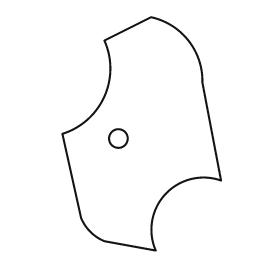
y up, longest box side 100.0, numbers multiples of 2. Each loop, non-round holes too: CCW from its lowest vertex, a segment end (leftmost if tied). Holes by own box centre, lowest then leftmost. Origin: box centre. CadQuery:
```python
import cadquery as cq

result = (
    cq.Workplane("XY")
    .moveTo(6.0, -50.0)
    .threePointArc((10.0, -26.0), (34.0, -20.0))
    .lineTo(26.0, 22.0)
    .threePointArc((20.0, 40.0), (4.0, 50.0))
    .lineTo(-16.0, 40.0)
    .threePointArc((-16.0, 16.0), (-34.0, 0.0))
    .lineTo(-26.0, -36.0)
    .threePointArc((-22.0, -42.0), (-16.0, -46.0))
    .close()
    .moveTo(-10.0, -2.0)
    .circle(4.0)
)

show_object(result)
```